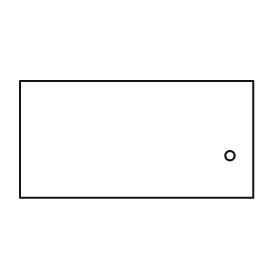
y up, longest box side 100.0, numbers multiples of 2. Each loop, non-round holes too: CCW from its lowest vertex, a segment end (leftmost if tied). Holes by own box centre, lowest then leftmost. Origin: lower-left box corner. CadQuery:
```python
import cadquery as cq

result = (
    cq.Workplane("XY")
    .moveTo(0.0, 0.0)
    .lineTo(100.0, 0.0)
    .lineTo(100.0, 50.0)
    .lineTo(0.0, 50.0)
    .close()
    .moveTo(90.0, 18.0)
    .circle(2.0)
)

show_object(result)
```